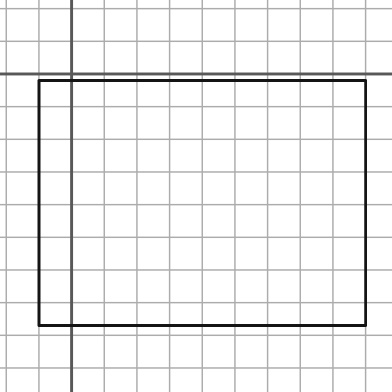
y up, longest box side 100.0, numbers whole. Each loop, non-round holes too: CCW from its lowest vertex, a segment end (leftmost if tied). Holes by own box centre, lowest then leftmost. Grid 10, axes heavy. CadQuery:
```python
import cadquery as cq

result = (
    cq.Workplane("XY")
    .moveTo(-10.0, -77.0)
    .lineTo(90.0, -77.0)
    .lineTo(90.0, -2.0)
    .lineTo(-10.0, -2.0)
    .close()
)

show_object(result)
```